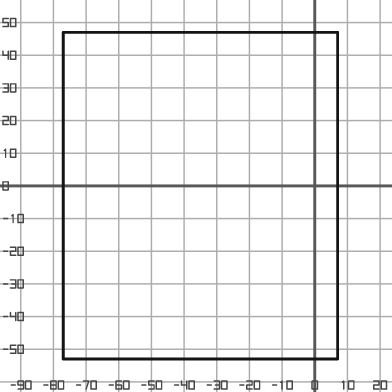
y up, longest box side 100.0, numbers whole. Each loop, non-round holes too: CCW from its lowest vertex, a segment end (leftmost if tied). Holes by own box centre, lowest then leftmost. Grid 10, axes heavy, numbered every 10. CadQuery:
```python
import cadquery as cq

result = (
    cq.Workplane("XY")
    .moveTo(-77.0, -53.0)
    .lineTo(7.0, -53.0)
    .lineTo(7.0, 47.0)
    .lineTo(-77.0, 47.0)
    .close()
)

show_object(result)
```